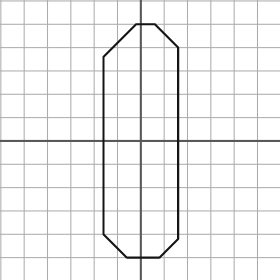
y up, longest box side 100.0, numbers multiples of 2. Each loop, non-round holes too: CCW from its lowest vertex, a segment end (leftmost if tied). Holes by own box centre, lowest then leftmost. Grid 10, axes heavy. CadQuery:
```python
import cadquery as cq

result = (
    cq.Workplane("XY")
    .moveTo(-6.0, -50.0)
    .lineTo(8.0, -50.0)
    .lineTo(16.0, -42.0)
    .lineTo(16.0, 40.0)
    .lineTo(6.0, 50.0)
    .lineTo(-2.0, 50.0)
    .lineTo(-16.0, 36.0)
    .lineTo(-16.0, -40.0)
    .close()
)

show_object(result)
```